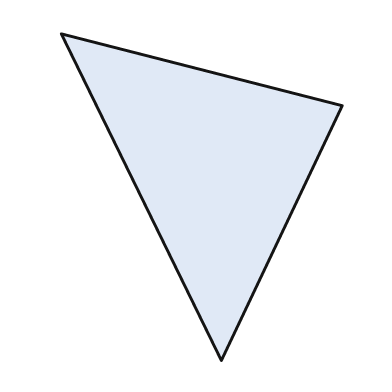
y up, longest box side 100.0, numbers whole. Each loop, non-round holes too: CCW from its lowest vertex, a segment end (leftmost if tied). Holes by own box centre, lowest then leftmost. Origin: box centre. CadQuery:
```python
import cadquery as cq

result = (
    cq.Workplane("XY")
    .moveTo(6.0, -50.0)
    .lineTo(43.0, 28.0)
    .lineTo(-43.0, 50.0)
    .close()
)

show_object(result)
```